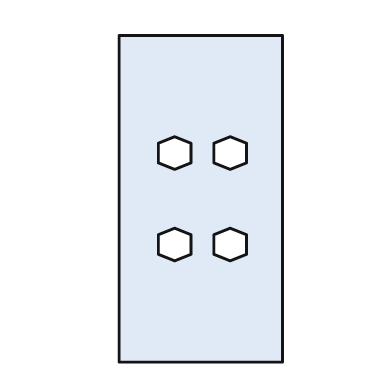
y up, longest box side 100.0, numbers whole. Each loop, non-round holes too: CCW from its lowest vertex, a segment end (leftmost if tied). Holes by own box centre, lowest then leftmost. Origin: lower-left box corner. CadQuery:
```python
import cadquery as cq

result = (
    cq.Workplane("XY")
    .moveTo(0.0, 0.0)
    .lineTo(50.0, 0.0)
    .lineTo(50.0, 100.0)
    .lineTo(0.0, 100.0)
    .close()
    .moveTo(17.0, 31.0)
    .lineTo(22.0, 33.0)
    .lineTo(22.0, 39.0)
    .lineTo(17.0, 41.0)
    .lineTo(12.0, 39.0)
    .lineTo(12.0, 33.0)
    .close()
    .moveTo(34.0, 31.0)
    .lineTo(39.0, 33.0)
    .lineTo(39.0, 39.0)
    .lineTo(34.0, 41.0)
    .lineTo(29.0, 39.0)
    .lineTo(29.0, 33.0)
    .close()
    .moveTo(17.0, 59.0)
    .lineTo(22.0, 61.0)
    .lineTo(22.0, 67.0)
    .lineTo(17.0, 69.0)
    .lineTo(12.0, 67.0)
    .lineTo(12.0, 61.0)
    .close()
    .moveTo(34.0, 59.0)
    .lineTo(39.0, 61.0)
    .lineTo(39.0, 67.0)
    .lineTo(34.0, 69.0)
    .lineTo(29.0, 67.0)
    .lineTo(29.0, 61.0)
    .close()
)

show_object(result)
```